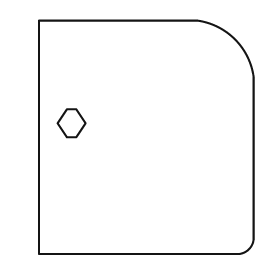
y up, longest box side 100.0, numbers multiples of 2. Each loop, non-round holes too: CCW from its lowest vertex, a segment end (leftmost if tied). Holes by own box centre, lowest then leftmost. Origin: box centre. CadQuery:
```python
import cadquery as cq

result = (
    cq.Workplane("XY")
    .moveTo(-46.0, -50.0)
    .lineTo(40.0, -50.0)
    .threePointArc((44.0, -48.0), (46.0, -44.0))
    .lineTo(46.0, 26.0)
    .threePointArc((38.0, 42.0), (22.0, 50.0))
    .lineTo(-46.0, 50.0)
    .close()
    .moveTo(-34.0, 0.0)
    .lineTo(-30.0, 0.0)
    .lineTo(-26.0, 6.0)
    .lineTo(-30.0, 12.0)
    .lineTo(-34.0, 12.0)
    .lineTo(-38.0, 6.0)
    .close()
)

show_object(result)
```